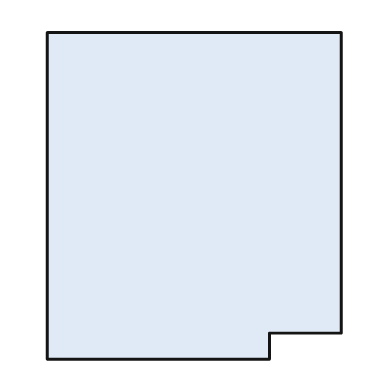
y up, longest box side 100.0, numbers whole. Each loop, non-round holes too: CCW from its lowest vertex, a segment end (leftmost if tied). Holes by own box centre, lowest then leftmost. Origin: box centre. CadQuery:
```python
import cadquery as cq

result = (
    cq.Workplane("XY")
    .moveTo(-45.0, -50.0)
    .lineTo(23.0, -50.0)
    .lineTo(23.0, -42.0)
    .lineTo(45.0, -42.0)
    .lineTo(45.0, 50.0)
    .lineTo(-45.0, 50.0)
    .close()
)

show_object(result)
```